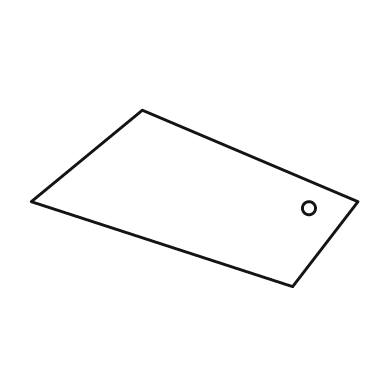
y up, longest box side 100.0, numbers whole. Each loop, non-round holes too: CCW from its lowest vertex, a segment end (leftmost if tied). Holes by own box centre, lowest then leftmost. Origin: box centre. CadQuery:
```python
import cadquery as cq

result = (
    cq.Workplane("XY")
    .moveTo(30.0, -27.0)
    .lineTo(50.0, -1.0)
    .lineTo(-16.0, 27.0)
    .lineTo(-50.0, -1.0)
    .close()
    .moveTo(35.0, -3.0)
    .circle(2.0)
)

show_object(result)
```